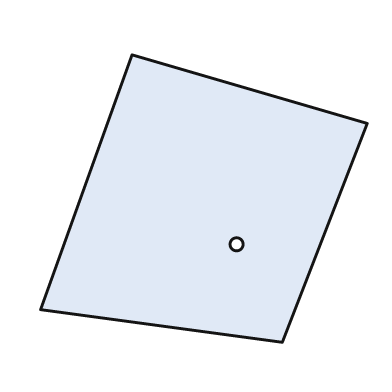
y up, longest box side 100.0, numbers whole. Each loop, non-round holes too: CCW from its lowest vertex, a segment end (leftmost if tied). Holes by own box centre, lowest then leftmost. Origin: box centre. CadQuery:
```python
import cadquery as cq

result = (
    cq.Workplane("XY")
    .moveTo(24.0, -44.0)
    .lineTo(50.0, 23.0)
    .lineTo(-22.0, 44.0)
    .lineTo(-50.0, -34.0)
    .close()
    .moveTo(10.0, -14.0)
    .circle(2.0)
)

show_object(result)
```